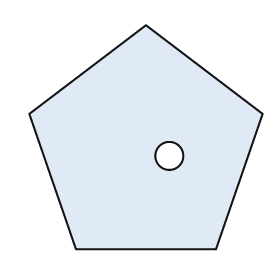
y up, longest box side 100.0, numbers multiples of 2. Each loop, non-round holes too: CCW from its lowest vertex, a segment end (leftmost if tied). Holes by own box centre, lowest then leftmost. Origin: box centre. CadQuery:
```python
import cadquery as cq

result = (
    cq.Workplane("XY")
    .moveTo(-30.0, -48.0)
    .lineTo(30.0, -48.0)
    .lineTo(50.0, 10.0)
    .lineTo(0.0, 48.0)
    .lineTo(-50.0, 10.0)
    .close()
    .moveTo(10.0, -8.0)
    .circle(6.0)
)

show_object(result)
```